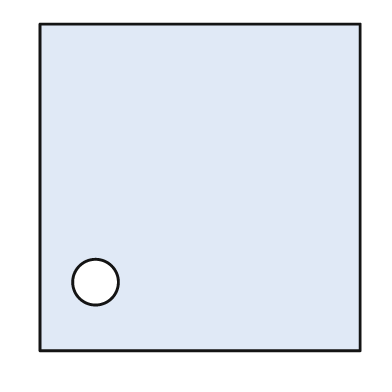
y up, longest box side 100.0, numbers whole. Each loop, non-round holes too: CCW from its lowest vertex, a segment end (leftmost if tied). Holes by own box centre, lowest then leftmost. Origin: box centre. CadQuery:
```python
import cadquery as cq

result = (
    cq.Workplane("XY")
    .moveTo(-49.0, -50.0)
    .lineTo(49.0, -50.0)
    .lineTo(49.0, 50.0)
    .lineTo(-49.0, 50.0)
    .close()
    .moveTo(-32.0, -29.0)
    .circle(7.0)
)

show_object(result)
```